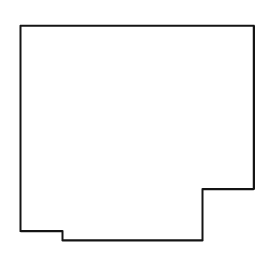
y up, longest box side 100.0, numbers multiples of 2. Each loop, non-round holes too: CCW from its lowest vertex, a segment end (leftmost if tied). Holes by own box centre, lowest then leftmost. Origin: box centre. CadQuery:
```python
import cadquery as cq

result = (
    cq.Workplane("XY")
    .moveTo(-32.0, -46.0)
    .lineTo(28.0, -46.0)
    .lineTo(28.0, -24.0)
    .lineTo(50.0, -24.0)
    .lineTo(50.0, 46.0)
    .lineTo(-50.0, 46.0)
    .lineTo(-50.0, -42.0)
    .lineTo(-32.0, -42.0)
    .close()
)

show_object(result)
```